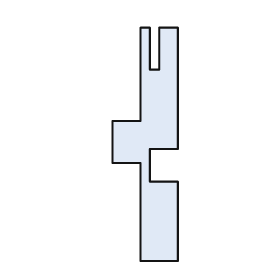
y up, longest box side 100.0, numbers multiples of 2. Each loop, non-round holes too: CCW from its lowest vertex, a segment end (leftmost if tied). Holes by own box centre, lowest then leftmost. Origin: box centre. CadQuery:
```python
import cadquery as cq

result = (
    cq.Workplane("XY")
    .moveTo(-2.0, -50.0)
    .lineTo(14.0, -50.0)
    .lineTo(14.0, -16.0)
    .lineTo(2.0, -16.0)
    .lineTo(2.0, -2.0)
    .lineTo(14.0, -2.0)
    .lineTo(14.0, 50.0)
    .lineTo(6.0, 50.0)
    .lineTo(6.0, 32.0)
    .lineTo(2.0, 32.0)
    .lineTo(2.0, 50.0)
    .lineTo(-2.0, 50.0)
    .lineTo(-2.0, 10.0)
    .lineTo(-14.0, 10.0)
    .lineTo(-14.0, -8.0)
    .lineTo(-2.0, -8.0)
    .close()
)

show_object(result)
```